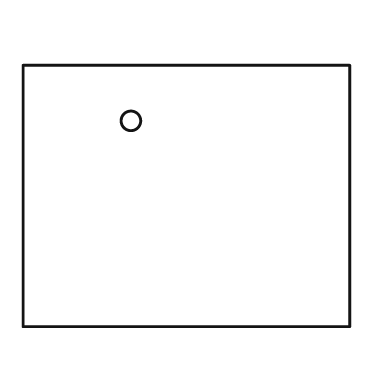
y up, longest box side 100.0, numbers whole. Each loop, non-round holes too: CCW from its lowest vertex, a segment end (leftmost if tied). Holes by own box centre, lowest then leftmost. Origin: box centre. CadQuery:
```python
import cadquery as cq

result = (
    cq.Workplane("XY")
    .moveTo(-50.0, -40.0)
    .lineTo(50.0, -40.0)
    .lineTo(50.0, 40.0)
    .lineTo(-50.0, 40.0)
    .close()
    .moveTo(-17.0, 23.0)
    .circle(3.0)
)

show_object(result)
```